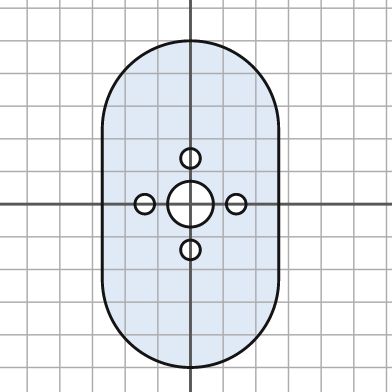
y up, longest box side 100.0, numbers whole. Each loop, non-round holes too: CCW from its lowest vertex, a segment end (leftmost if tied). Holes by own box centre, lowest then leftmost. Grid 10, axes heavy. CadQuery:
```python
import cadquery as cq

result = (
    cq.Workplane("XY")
    .moveTo(-27.0, -23.0)
    .threePointArc((0.0, -50.0), (27.0, -23.0))
    .lineTo(27.0, 23.0)
    .threePointArc((0.0, 50.0), (-27.0, 23.0))
    .close()
    .moveTo(0.0, -14.0)
    .circle(3.0)
    .moveTo(-14.0, 0.0)
    .circle(3.0)
    .moveTo(0.0, 0.0)
    .circle(7.0)
    .moveTo(14.0, 0.0)
    .circle(3.0)
    .moveTo(0.0, 14.0)
    .circle(3.0)
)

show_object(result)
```